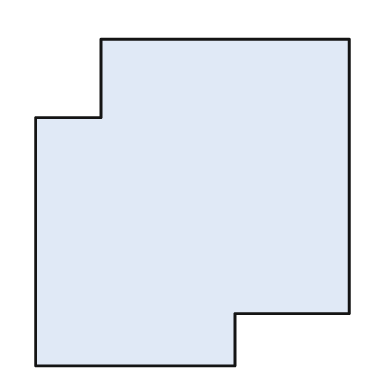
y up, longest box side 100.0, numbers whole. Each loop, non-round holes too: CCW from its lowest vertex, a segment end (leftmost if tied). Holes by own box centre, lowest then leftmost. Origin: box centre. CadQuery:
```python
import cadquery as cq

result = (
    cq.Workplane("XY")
    .moveTo(-48.0, -50.0)
    .lineTo(13.0, -50.0)
    .lineTo(13.0, -34.0)
    .lineTo(48.0, -34.0)
    .lineTo(48.0, 50.0)
    .lineTo(-28.0, 50.0)
    .lineTo(-28.0, 26.0)
    .lineTo(-48.0, 26.0)
    .close()
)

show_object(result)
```